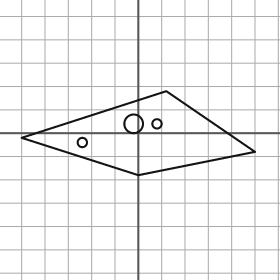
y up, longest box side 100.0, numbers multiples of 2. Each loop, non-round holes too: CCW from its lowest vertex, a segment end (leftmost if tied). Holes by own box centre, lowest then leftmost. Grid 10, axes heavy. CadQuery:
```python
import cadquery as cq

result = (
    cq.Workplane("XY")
    .moveTo(0.0, -18.0)
    .lineTo(50.0, -8.0)
    .lineTo(12.0, 18.0)
    .lineTo(-50.0, -2.0)
    .close()
    .moveTo(-24.0, -4.0)
    .circle(2.0)
    .moveTo(-2.0, 4.0)
    .circle(4.0)
    .moveTo(8.0, 4.0)
    .circle(2.0)
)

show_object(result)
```